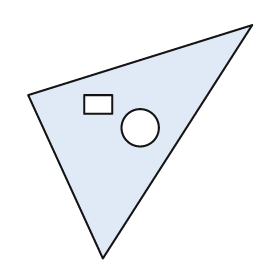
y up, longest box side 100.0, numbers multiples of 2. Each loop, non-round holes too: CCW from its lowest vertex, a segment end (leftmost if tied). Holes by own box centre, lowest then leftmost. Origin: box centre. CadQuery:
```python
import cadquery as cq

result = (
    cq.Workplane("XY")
    .moveTo(-16.0, -50.0)
    .lineTo(48.0, 50.0)
    .lineTo(-48.0, 20.0)
    .close()
    .moveTo(0.0, 6.0)
    .circle(8.0)
    .moveTo(-24.0, 12.0)
    .lineTo(-12.0, 12.0)
    .lineTo(-12.0, 20.0)
    .lineTo(-24.0, 20.0)
    .close()
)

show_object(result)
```